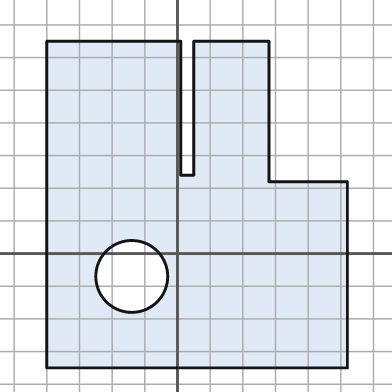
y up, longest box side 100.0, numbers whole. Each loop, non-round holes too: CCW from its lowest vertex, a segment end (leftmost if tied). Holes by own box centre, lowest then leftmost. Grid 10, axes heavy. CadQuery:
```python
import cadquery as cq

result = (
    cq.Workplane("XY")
    .moveTo(-40.0, -35.0)
    .lineTo(52.0, -35.0)
    .lineTo(52.0, 22.0)
    .lineTo(28.0, 22.0)
    .lineTo(28.0, 65.0)
    .lineTo(5.0, 65.0)
    .lineTo(5.0, 24.0)
    .lineTo(1.0, 24.0)
    .lineTo(1.0, 65.0)
    .lineTo(-40.0, 65.0)
    .close()
    .moveTo(-14.0, -7.0)
    .circle(11.0)
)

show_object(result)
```